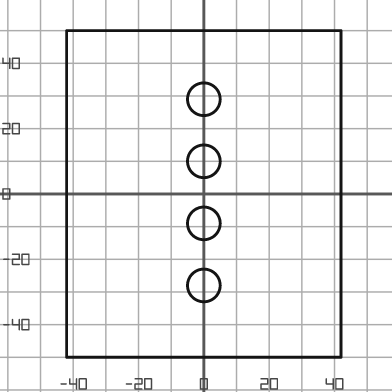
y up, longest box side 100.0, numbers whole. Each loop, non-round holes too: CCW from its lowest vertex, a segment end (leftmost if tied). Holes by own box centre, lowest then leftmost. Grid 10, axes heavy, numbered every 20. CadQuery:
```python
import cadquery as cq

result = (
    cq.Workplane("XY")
    .moveTo(-42.0, -50.0)
    .lineTo(42.0, -50.0)
    .lineTo(42.0, 50.0)
    .lineTo(-42.0, 50.0)
    .close()
    .moveTo(0.0, -28.0)
    .circle(5.0)
    .moveTo(0.0, -9.0)
    .circle(5.0)
    .moveTo(0.0, 10.0)
    .circle(5.0)
    .moveTo(0.0, 29.0)
    .circle(5.0)
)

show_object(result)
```